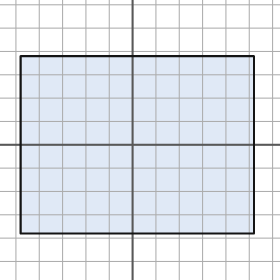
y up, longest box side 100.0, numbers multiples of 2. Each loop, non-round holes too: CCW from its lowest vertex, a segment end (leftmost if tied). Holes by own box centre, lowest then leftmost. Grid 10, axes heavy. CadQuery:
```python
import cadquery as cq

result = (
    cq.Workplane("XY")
    .moveTo(-48.0, -38.0)
    .lineTo(52.0, -38.0)
    .lineTo(52.0, 38.0)
    .lineTo(-48.0, 38.0)
    .close()
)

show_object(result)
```